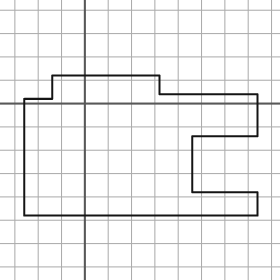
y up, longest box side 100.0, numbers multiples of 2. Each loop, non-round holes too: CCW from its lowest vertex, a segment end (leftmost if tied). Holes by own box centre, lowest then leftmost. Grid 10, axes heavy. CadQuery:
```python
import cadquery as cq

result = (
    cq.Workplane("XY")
    .moveTo(-26.0, -48.0)
    .lineTo(74.0, -48.0)
    .lineTo(74.0, -38.0)
    .lineTo(46.0, -38.0)
    .lineTo(46.0, -14.0)
    .lineTo(74.0, -14.0)
    .lineTo(74.0, 4.0)
    .lineTo(32.0, 4.0)
    .lineTo(32.0, 12.0)
    .lineTo(-14.0, 12.0)
    .lineTo(-14.0, 2.0)
    .lineTo(-26.0, 2.0)
    .close()
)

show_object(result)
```